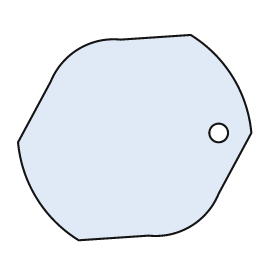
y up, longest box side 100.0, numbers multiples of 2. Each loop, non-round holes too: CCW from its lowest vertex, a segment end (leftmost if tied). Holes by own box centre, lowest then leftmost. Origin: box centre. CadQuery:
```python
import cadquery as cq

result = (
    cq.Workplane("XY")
    .moveTo(-24.0, -44.0)
    .lineTo(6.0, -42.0)
    .threePointArc((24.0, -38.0), (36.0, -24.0))
    .lineTo(50.0, 2.0)
    .threePointArc((42.0, 26.0), (24.0, 44.0))
    .lineTo(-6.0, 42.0)
    .threePointArc((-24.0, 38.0), (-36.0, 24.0))
    .lineTo(-50.0, -2.0)
    .threePointArc((-42.0, -26.0), (-24.0, -44.0))
    .close()
    .moveTo(36.0, 2.0)
    .circle(4.0)
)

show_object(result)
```